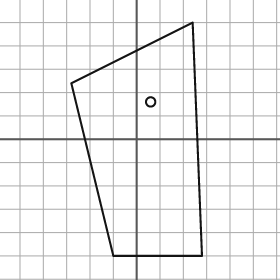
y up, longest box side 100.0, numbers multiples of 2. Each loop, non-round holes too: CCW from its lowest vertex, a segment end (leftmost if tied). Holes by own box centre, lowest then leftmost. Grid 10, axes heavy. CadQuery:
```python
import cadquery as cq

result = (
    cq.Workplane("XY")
    .moveTo(-10.0, -50.0)
    .lineTo(28.0, -50.0)
    .lineTo(24.0, 50.0)
    .lineTo(-28.0, 24.0)
    .close()
    .moveTo(6.0, 16.0)
    .circle(2.0)
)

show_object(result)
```